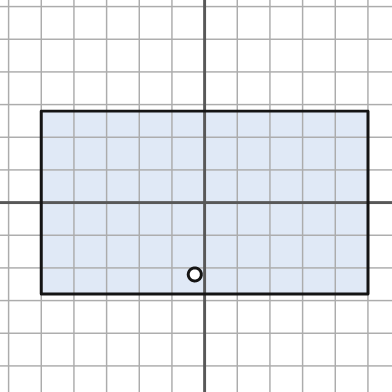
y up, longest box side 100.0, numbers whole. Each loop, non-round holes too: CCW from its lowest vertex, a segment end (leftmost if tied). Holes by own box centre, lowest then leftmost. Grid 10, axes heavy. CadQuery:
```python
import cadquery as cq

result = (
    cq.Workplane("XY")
    .moveTo(-50.0, -28.0)
    .lineTo(50.0, -28.0)
    .lineTo(50.0, 28.0)
    .lineTo(-50.0, 28.0)
    .close()
    .moveTo(-3.0, -22.0)
    .circle(2.0)
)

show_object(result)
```